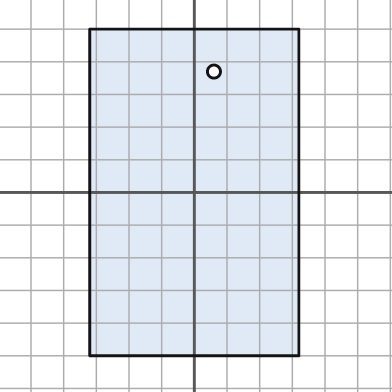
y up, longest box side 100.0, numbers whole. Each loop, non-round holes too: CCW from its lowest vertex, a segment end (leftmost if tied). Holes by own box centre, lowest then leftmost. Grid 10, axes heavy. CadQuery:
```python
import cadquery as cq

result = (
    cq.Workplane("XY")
    .moveTo(-32.0, -50.0)
    .lineTo(32.0, -50.0)
    .lineTo(32.0, 50.0)
    .lineTo(-32.0, 50.0)
    .close()
    .moveTo(6.0, 37.0)
    .circle(2.0)
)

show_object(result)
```